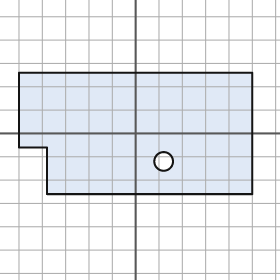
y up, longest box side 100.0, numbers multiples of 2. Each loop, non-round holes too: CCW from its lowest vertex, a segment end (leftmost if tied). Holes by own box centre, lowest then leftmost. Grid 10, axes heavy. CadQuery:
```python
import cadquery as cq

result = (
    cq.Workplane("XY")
    .moveTo(-38.0, -26.0)
    .lineTo(50.0, -26.0)
    .lineTo(50.0, 26.0)
    .lineTo(-50.0, 26.0)
    .lineTo(-50.0, -6.0)
    .lineTo(-38.0, -6.0)
    .close()
    .moveTo(12.0, -12.0)
    .circle(4.0)
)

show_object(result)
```